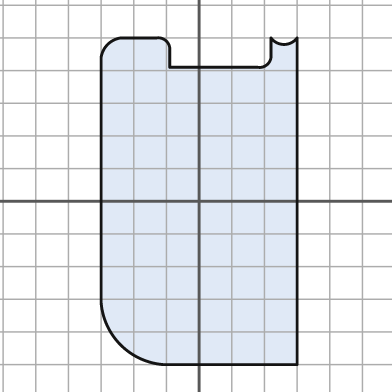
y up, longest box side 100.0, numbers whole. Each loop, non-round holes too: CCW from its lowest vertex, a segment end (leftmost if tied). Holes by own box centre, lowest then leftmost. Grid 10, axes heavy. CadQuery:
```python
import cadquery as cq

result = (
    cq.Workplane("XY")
    .moveTo(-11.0, -50.0)
    .lineTo(30.0, -50.0)
    .lineTo(30.0, 50.0)
    .threePointArc((26.0, 48.0), (22.0, 50.0))
    .lineTo(22.0, 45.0)
    .threePointArc((21.0, 42.0), (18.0, 41.0))
    .lineTo(-9.0, 41.0)
    .lineTo(-9.0, 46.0)
    .threePointArc((-10.0, 49.0), (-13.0, 50.0))
    .lineTo(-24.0, 50.0)
    .threePointArc((-28.0, 48.0), (-30.0, 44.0))
    .lineTo(-30.0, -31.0)
    .threePointArc((-24.0, -44.0), (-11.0, -50.0))
    .close()
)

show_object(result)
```